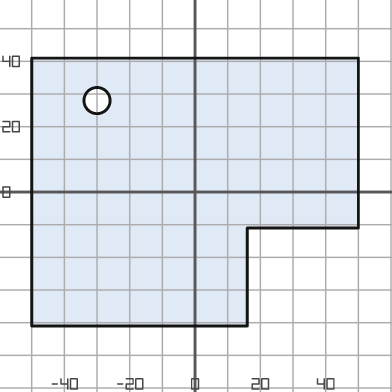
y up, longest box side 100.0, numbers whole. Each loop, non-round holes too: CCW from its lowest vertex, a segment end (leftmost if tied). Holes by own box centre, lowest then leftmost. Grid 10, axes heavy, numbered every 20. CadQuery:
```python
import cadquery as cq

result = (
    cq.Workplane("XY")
    .moveTo(-50.0, -41.0)
    .lineTo(16.0, -41.0)
    .lineTo(16.0, -11.0)
    .lineTo(50.0, -11.0)
    .lineTo(50.0, 41.0)
    .lineTo(-50.0, 41.0)
    .close()
    .moveTo(-30.0, 28.0)
    .circle(4.0)
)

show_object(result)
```